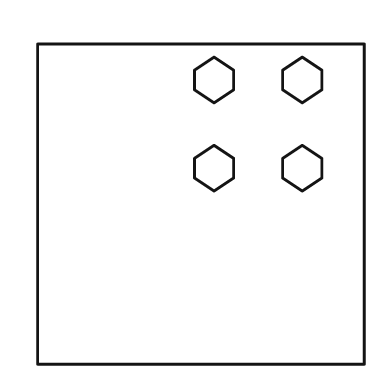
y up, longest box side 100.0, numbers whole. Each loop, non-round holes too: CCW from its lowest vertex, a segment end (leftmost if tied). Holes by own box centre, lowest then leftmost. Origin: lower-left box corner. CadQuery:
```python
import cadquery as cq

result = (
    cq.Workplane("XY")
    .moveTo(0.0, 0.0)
    .lineTo(100.0, 0.0)
    .lineTo(100.0, 98.0)
    .lineTo(0.0, 98.0)
    .close()
    .moveTo(54.0, 53.0)
    .lineTo(60.0, 57.0)
    .lineTo(60.0, 63.0)
    .lineTo(54.0, 67.0)
    .lineTo(48.0, 63.0)
    .lineTo(48.0, 57.0)
    .close()
    .moveTo(81.0, 53.0)
    .lineTo(87.0, 57.0)
    .lineTo(87.0, 63.0)
    .lineTo(81.0, 67.0)
    .lineTo(75.0, 63.0)
    .lineTo(75.0, 57.0)
    .close()
    .moveTo(54.0, 80.0)
    .lineTo(60.0, 84.0)
    .lineTo(60.0, 90.0)
    .lineTo(54.0, 94.0)
    .lineTo(48.0, 90.0)
    .lineTo(48.0, 84.0)
    .close()
    .moveTo(81.0, 80.0)
    .lineTo(87.0, 84.0)
    .lineTo(87.0, 90.0)
    .lineTo(81.0, 94.0)
    .lineTo(75.0, 90.0)
    .lineTo(75.0, 84.0)
    .close()
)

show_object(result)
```